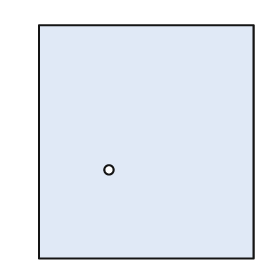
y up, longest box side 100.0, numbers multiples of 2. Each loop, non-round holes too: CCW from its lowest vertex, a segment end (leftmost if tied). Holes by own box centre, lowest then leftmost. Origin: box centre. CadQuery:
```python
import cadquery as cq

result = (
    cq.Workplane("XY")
    .moveTo(-46.0, -50.0)
    .lineTo(46.0, -50.0)
    .lineTo(46.0, 50.0)
    .lineTo(-46.0, 50.0)
    .close()
    .moveTo(-16.0, -12.0)
    .circle(2.0)
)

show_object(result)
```